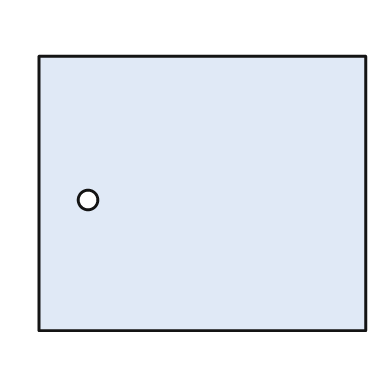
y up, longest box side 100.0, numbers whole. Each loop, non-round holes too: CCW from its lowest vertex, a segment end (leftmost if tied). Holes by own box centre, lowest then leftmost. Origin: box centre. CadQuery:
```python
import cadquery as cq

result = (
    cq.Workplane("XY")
    .moveTo(-50.0, -42.0)
    .lineTo(50.0, -42.0)
    .lineTo(50.0, 42.0)
    .lineTo(-50.0, 42.0)
    .close()
    .moveTo(-35.0, -2.0)
    .circle(3.0)
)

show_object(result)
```